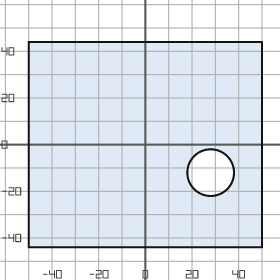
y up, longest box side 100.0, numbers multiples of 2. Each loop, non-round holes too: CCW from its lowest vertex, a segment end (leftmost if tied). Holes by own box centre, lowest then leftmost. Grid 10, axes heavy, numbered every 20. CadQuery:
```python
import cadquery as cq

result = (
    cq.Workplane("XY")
    .moveTo(-50.0, -44.0)
    .lineTo(50.0, -44.0)
    .lineTo(50.0, 44.0)
    .lineTo(-50.0, 44.0)
    .close()
    .moveTo(28.0, -12.0)
    .circle(10.0)
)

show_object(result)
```